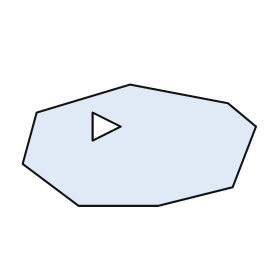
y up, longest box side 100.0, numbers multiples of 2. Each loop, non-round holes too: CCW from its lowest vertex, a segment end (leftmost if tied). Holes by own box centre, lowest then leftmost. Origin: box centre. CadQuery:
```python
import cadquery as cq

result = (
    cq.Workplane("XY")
    .moveTo(-26.0, -26.0)
    .lineTo(8.0, -26.0)
    .lineTo(40.0, -18.0)
    .lineTo(50.0, 8.0)
    .lineTo(38.0, 18.0)
    .lineTo(-4.0, 26.0)
    .lineTo(-44.0, 14.0)
    .lineTo(-50.0, -8.0)
    .close()
    .moveTo(-20.0, 2.0)
    .lineTo(-8.0, 8.0)
    .lineTo(-20.0, 14.0)
    .close()
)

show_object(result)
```